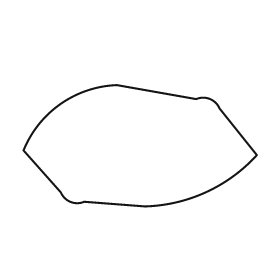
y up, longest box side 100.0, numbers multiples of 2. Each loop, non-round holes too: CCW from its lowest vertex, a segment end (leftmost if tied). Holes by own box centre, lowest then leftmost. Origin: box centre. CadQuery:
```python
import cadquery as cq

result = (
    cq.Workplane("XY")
    .moveTo(2.0, -26.0)
    .threePointArc((28.0, -20.0), (50.0, -4.0))
    .lineTo(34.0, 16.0)
    .threePointArc((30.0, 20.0), (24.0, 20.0))
    .lineTo(-10.0, 26.0)
    .threePointArc((-34.0, 18.0), (-50.0, -2.0))
    .lineTo(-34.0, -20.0)
    .threePointArc((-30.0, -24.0), (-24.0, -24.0))
    .close()
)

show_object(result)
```